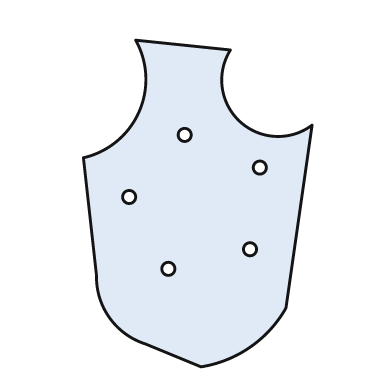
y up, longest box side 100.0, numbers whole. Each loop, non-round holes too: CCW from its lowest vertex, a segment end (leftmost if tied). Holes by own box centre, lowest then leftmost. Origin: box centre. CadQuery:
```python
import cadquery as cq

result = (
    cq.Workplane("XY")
    .moveTo(1.0, -50.0)
    .threePointArc((16.0, -44.0), (27.0, -32.0))
    .lineTo(35.0, 24.0)
    .threePointArc((13.0, 25.0), (10.0, 47.0))
    .lineTo(-19.0, 50.0)
    .threePointArc((-18.0, 28.0), (-35.0, 14.0))
    .lineTo(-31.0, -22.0)
    .threePointArc((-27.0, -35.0), (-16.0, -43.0))
    .close()
    .moveTo(-9.0, -20.0)
    .circle(2.0)
    .moveTo(16.0, -14.0)
    .circle(2.0)
    .moveTo(-21.0, 2.0)
    .circle(2.0)
    .moveTo(19.0, 11.0)
    .circle(2.0)
    .moveTo(-4.0, 21.0)
    .circle(2.0)
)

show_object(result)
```